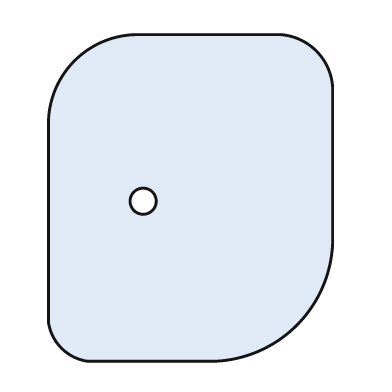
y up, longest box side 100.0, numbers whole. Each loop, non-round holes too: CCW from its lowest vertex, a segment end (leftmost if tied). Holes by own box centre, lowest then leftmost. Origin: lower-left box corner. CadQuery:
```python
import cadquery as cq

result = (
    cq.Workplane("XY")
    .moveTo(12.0, 0.0)
    .lineTo(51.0, 0.0)
    .threePointArc((76.0, 11.0), (87.0, 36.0))
    .lineTo(87.0, 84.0)
    .threePointArc((82.0, 95.0), (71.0, 100.0))
    .lineTo(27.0, 100.0)
    .threePointArc((8.0, 92.0), (0.0, 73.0))
    .lineTo(0.0, 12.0)
    .threePointArc((4.0, 4.0), (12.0, 0.0))
    .close()
    .moveTo(29.0, 49.0)
    .circle(4.0)
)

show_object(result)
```